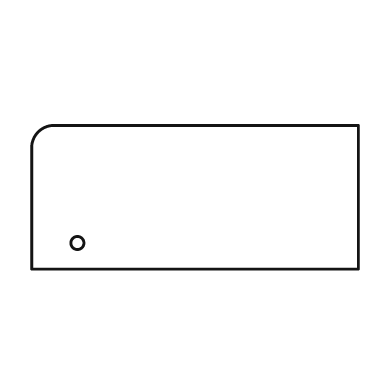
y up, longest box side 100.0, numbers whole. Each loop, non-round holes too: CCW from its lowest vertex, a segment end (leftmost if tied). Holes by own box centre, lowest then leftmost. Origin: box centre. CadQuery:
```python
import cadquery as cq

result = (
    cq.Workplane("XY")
    .moveTo(-50.0, -22.0)
    .lineTo(50.0, -22.0)
    .lineTo(50.0, 22.0)
    .lineTo(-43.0, 22.0)
    .threePointArc((-48.0, 20.0), (-50.0, 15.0))
    .close()
    .moveTo(-36.0, -14.0)
    .circle(2.0)
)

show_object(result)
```